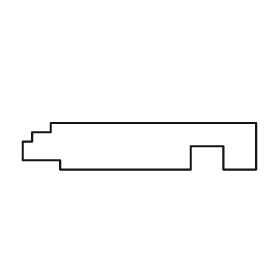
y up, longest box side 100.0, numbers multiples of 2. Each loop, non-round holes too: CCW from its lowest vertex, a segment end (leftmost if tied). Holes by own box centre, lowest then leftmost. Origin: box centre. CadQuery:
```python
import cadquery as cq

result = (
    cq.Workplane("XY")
    .moveTo(-34.0, -10.0)
    .lineTo(22.0, -10.0)
    .lineTo(22.0, 0.0)
    .lineTo(36.0, 0.0)
    .lineTo(36.0, -10.0)
    .lineTo(50.0, -10.0)
    .lineTo(50.0, 10.0)
    .lineTo(-38.0, 10.0)
    .lineTo(-38.0, 6.0)
    .lineTo(-46.0, 6.0)
    .lineTo(-46.0, 2.0)
    .lineTo(-50.0, 2.0)
    .lineTo(-50.0, -6.0)
    .lineTo(-34.0, -6.0)
    .close()
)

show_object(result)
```